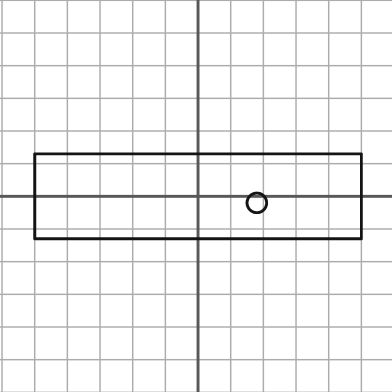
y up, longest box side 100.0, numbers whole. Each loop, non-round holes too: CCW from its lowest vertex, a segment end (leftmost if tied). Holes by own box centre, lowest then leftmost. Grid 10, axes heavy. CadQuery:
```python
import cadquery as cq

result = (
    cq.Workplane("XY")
    .moveTo(-50.0, -13.0)
    .lineTo(50.0, -13.0)
    .lineTo(50.0, 13.0)
    .lineTo(-50.0, 13.0)
    .close()
    .moveTo(18.0, -2.0)
    .circle(3.0)
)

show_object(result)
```